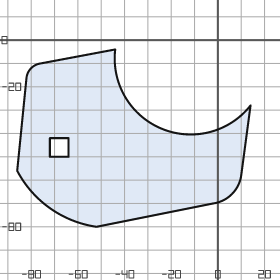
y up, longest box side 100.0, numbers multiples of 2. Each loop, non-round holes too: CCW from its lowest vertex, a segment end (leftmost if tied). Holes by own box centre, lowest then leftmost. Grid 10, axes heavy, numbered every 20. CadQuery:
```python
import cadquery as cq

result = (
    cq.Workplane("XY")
    .moveTo(-52.0, -80.0)
    .lineTo(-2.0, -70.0)
    .threePointArc((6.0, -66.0), (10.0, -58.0))
    .lineTo(14.0, -28.0)
    .threePointArc((-24.0, -38.0), (-44.0, -4.0))
    .lineTo(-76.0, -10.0)
    .threePointArc((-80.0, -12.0), (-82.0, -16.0))
    .lineTo(-86.0, -56.0)
    .threePointArc((-72.0, -72.0), (-52.0, -80.0))
    .close()
    .moveTo(-72.0, -50.0)
    .lineTo(-64.0, -50.0)
    .lineTo(-64.0, -42.0)
    .lineTo(-72.0, -42.0)
    .close()
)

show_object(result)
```